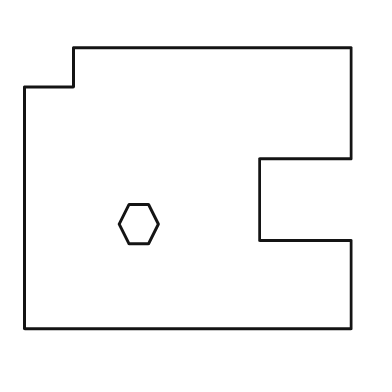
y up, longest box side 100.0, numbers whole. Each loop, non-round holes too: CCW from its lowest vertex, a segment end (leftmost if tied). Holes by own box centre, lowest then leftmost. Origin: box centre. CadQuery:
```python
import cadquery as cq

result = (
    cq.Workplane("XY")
    .moveTo(-50.0, -43.0)
    .lineTo(50.0, -43.0)
    .lineTo(50.0, -16.0)
    .lineTo(22.0, -16.0)
    .lineTo(22.0, 9.0)
    .lineTo(50.0, 9.0)
    .lineTo(50.0, 43.0)
    .lineTo(-35.0, 43.0)
    .lineTo(-35.0, 31.0)
    .lineTo(-50.0, 31.0)
    .close()
    .moveTo(-18.0, -17.0)
    .lineTo(-12.0, -17.0)
    .lineTo(-9.0, -11.0)
    .lineTo(-12.0, -5.0)
    .lineTo(-18.0, -5.0)
    .lineTo(-21.0, -11.0)
    .close()
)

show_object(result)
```